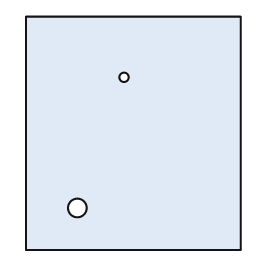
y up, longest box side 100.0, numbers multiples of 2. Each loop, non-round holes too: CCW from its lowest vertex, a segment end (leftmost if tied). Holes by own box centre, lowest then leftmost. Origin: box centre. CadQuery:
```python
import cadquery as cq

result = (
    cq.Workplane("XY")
    .moveTo(-46.0, -50.0)
    .lineTo(46.0, -50.0)
    .lineTo(46.0, 50.0)
    .lineTo(-46.0, 50.0)
    .close()
    .moveTo(-24.0, -32.0)
    .circle(4.0)
    .moveTo(-4.0, 24.0)
    .circle(2.0)
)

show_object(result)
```